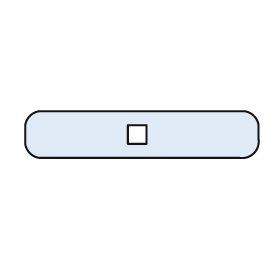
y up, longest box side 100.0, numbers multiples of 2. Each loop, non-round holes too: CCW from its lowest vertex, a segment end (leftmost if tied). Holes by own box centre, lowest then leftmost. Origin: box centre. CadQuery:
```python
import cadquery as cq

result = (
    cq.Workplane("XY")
    .moveTo(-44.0, -10.0)
    .lineTo(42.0, -10.0)
    .threePointArc((48.0, -8.0), (50.0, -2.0))
    .lineTo(50.0, 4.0)
    .threePointArc((48.0, 8.0), (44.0, 10.0))
    .lineTo(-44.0, 10.0)
    .threePointArc((-48.0, 8.0), (-50.0, 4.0))
    .lineTo(-50.0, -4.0)
    .threePointArc((-48.0, -8.0), (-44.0, -10.0))
    .close()
    .moveTo(-6.0, -4.0)
    .lineTo(2.0, -4.0)
    .lineTo(2.0, 4.0)
    .lineTo(-6.0, 4.0)
    .close()
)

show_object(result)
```